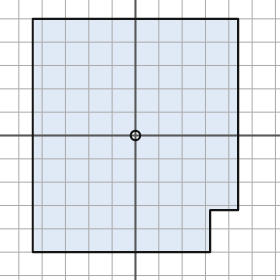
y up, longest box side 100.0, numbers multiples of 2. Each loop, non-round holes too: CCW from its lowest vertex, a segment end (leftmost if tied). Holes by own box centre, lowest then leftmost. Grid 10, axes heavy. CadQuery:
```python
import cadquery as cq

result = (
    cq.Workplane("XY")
    .moveTo(-44.0, -50.0)
    .lineTo(32.0, -50.0)
    .lineTo(32.0, -32.0)
    .lineTo(44.0, -32.0)
    .lineTo(44.0, 50.0)
    .lineTo(-44.0, 50.0)
    .close()
    .moveTo(0.0, 0.0)
    .circle(2.0)
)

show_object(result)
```